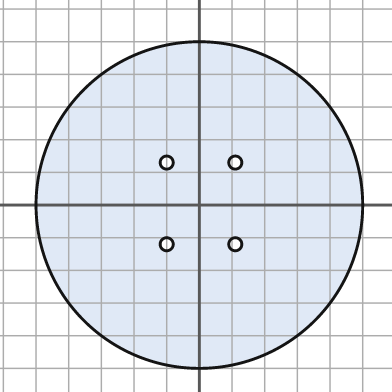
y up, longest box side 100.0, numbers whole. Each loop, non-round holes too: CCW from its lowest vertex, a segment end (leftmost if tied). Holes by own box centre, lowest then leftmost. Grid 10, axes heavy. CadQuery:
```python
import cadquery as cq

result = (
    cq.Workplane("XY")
    .moveTo(0.0, 0.0)
    .circle(50.0)
    .moveTo(-10.0, -12.0)
    .circle(2.0)
    .moveTo(11.0, -12.0)
    .circle(2.0)
    .moveTo(-10.0, 13.0)
    .circle(2.0)
    .moveTo(11.0, 13.0)
    .circle(2.0)
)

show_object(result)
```